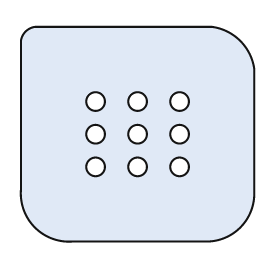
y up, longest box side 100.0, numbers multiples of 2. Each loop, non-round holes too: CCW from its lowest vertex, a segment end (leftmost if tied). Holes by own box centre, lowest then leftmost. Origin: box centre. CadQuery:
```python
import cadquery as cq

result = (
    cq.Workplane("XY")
    .moveTo(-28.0, -46.0)
    .lineTo(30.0, -46.0)
    .threePointArc((44.0, -40.0), (50.0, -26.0))
    .lineTo(50.0, 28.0)
    .threePointArc((44.0, 40.0), (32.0, 46.0))
    .lineTo(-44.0, 46.0)
    .threePointArc((-48.0, 44.0), (-50.0, 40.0))
    .lineTo(-50.0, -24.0)
    .threePointArc((-44.0, -40.0), (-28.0, -46.0))
    .close()
    .moveTo(-18.0, -14.0)
    .circle(4.0)
    .moveTo(0.0, -14.0)
    .circle(4.0)
    .moveTo(18.0, -14.0)
    .circle(4.0)
    .moveTo(-18.0, 0.0)
    .circle(4.0)
    .moveTo(0.0, 0.0)
    .circle(4.0)
    .moveTo(18.0, 0.0)
    .circle(4.0)
    .moveTo(-18.0, 14.0)
    .circle(4.0)
    .moveTo(0.0, 14.0)
    .circle(4.0)
    .moveTo(18.0, 14.0)
    .circle(4.0)
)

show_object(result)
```